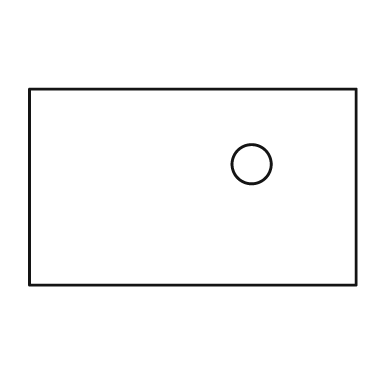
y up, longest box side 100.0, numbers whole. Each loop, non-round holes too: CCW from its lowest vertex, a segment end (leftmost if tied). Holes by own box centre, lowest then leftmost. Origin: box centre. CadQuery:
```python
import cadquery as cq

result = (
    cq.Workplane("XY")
    .moveTo(-50.0, -30.0)
    .lineTo(50.0, -30.0)
    .lineTo(50.0, 30.0)
    .lineTo(-50.0, 30.0)
    .close()
    .moveTo(18.0, 7.0)
    .circle(6.0)
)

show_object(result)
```